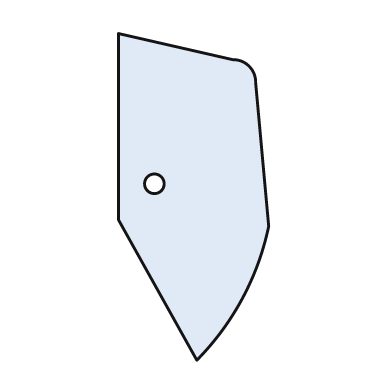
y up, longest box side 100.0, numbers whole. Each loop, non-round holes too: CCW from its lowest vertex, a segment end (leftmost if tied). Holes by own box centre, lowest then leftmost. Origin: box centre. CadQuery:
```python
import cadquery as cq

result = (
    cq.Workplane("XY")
    .moveTo(1.0, -50.0)
    .threePointArc((15.0, -31.0), (23.0, -9.0))
    .lineTo(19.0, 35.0)
    .threePointArc((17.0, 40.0), (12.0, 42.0))
    .lineTo(-23.0, 50.0)
    .lineTo(-23.0, -7.0)
    .close()
    .moveTo(-12.0, 4.0)
    .circle(3.0)
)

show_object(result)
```